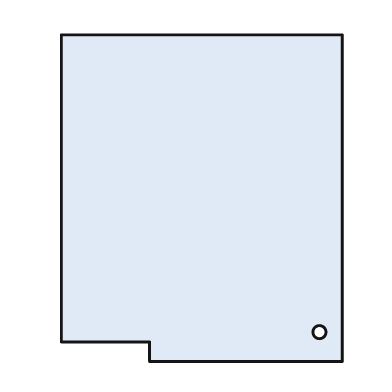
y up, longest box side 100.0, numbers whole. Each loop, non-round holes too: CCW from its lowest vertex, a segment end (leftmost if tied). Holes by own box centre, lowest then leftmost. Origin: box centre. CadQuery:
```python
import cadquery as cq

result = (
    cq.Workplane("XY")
    .moveTo(-16.0, -50.0)
    .lineTo(43.0, -50.0)
    .lineTo(43.0, 50.0)
    .lineTo(-43.0, 50.0)
    .lineTo(-43.0, -44.0)
    .lineTo(-16.0, -44.0)
    .close()
    .moveTo(36.0, -41.0)
    .circle(2.0)
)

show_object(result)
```